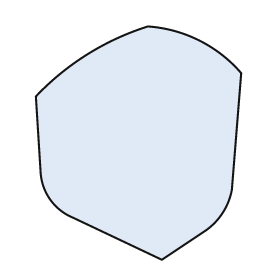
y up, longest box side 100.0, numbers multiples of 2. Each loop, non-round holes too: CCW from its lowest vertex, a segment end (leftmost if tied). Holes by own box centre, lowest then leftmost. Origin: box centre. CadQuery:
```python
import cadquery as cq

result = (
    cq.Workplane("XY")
    .moveTo(10.0, -50.0)
    .lineTo(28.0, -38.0)
    .threePointArc((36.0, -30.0), (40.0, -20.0))
    .lineTo(44.0, 30.0)
    .threePointArc((26.0, 44.0), (4.0, 50.0))
    .threePointArc((-22.0, 38.0), (-44.0, 20.0))
    .lineTo(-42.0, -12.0)
    .threePointArc((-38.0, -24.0), (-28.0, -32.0))
    .close()
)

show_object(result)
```